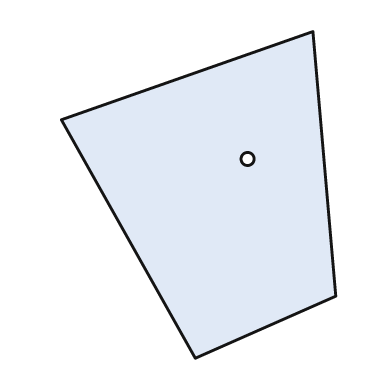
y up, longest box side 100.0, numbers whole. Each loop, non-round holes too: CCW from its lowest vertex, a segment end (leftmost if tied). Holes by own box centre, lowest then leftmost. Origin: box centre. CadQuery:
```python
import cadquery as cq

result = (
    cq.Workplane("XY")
    .moveTo(-1.0, -50.0)
    .lineTo(42.0, -31.0)
    .lineTo(35.0, 50.0)
    .lineTo(-42.0, 23.0)
    .close()
    .moveTo(15.0, 11.0)
    .circle(2.0)
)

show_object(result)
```